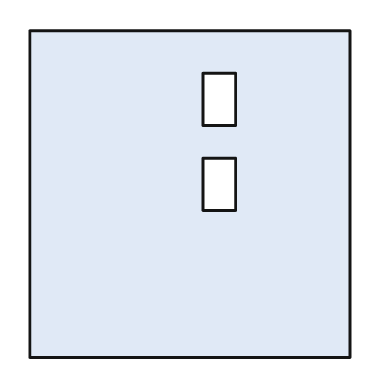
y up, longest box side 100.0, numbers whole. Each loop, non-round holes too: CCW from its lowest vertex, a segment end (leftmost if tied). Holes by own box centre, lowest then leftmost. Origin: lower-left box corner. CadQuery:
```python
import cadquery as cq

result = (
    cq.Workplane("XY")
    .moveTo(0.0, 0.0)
    .lineTo(98.0, 0.0)
    .lineTo(98.0, 100.0)
    .lineTo(0.0, 100.0)
    .close()
    .moveTo(53.0, 45.0)
    .lineTo(63.0, 45.0)
    .lineTo(63.0, 61.0)
    .lineTo(53.0, 61.0)
    .close()
    .moveTo(53.0, 71.0)
    .lineTo(63.0, 71.0)
    .lineTo(63.0, 87.0)
    .lineTo(53.0, 87.0)
    .close()
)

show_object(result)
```